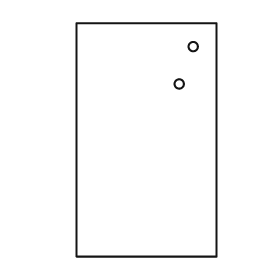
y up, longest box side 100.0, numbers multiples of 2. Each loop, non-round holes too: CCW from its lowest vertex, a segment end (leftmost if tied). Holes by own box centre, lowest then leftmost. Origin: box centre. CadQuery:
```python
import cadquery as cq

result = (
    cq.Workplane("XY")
    .moveTo(-30.0, -50.0)
    .lineTo(30.0, -50.0)
    .lineTo(30.0, 50.0)
    .lineTo(-30.0, 50.0)
    .close()
    .moveTo(14.0, 24.0)
    .circle(2.0)
    .moveTo(20.0, 40.0)
    .circle(2.0)
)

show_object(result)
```